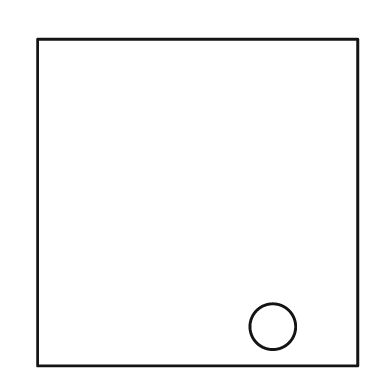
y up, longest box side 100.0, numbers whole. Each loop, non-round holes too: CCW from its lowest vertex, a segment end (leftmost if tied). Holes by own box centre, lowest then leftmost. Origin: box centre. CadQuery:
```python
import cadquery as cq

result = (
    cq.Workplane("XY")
    .moveTo(-49.0, -50.0)
    .lineTo(49.0, -50.0)
    .lineTo(49.0, 50.0)
    .lineTo(-49.0, 50.0)
    .close()
    .moveTo(23.0, -38.0)
    .circle(7.0)
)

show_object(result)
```